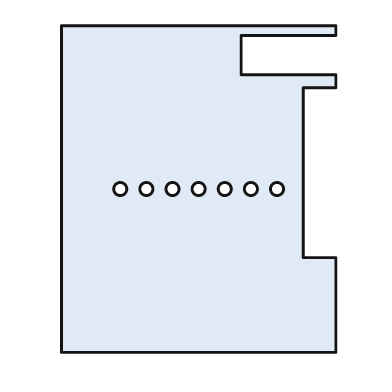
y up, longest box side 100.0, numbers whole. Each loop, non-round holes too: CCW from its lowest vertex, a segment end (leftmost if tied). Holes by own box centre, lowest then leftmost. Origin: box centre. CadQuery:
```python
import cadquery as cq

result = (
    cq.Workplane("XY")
    .moveTo(-42.0, -50.0)
    .lineTo(42.0, -50.0)
    .lineTo(42.0, -21.0)
    .lineTo(32.0, -21.0)
    .lineTo(32.0, 31.0)
    .lineTo(42.0, 31.0)
    .lineTo(42.0, 35.0)
    .lineTo(13.0, 35.0)
    .lineTo(13.0, 47.0)
    .lineTo(42.0, 47.0)
    .lineTo(42.0, 50.0)
    .lineTo(-42.0, 50.0)
    .close()
    .moveTo(-24.0, 0.0)
    .circle(2.0)
    .moveTo(-16.0, 0.0)
    .circle(2.0)
    .moveTo(-8.0, 0.0)
    .circle(2.0)
    .moveTo(0.0, 0.0)
    .circle(2.0)
    .moveTo(8.0, 0.0)
    .circle(2.0)
    .moveTo(16.0, 0.0)
    .circle(2.0)
    .moveTo(24.0, 0.0)
    .circle(2.0)
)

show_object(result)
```